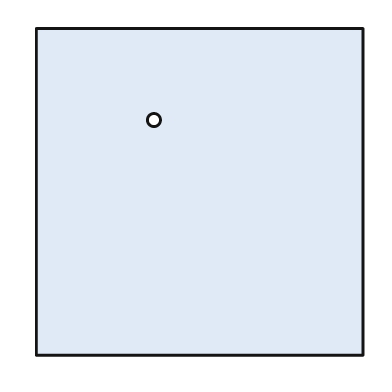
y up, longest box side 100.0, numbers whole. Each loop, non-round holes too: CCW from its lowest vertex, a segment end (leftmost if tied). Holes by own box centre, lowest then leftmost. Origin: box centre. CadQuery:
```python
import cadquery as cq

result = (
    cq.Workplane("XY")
    .moveTo(-50.0, -50.0)
    .lineTo(50.0, -50.0)
    .lineTo(50.0, 50.0)
    .lineTo(-50.0, 50.0)
    .close()
    .moveTo(-14.0, 22.0)
    .circle(2.0)
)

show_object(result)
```